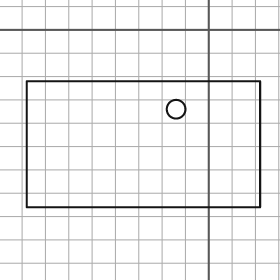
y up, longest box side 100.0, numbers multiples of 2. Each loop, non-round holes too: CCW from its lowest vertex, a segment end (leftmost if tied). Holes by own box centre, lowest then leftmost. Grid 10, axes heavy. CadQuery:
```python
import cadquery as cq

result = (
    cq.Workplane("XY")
    .moveTo(-78.0, -76.0)
    .lineTo(22.0, -76.0)
    .lineTo(22.0, -22.0)
    .lineTo(-78.0, -22.0)
    .close()
    .moveTo(-14.0, -34.0)
    .circle(4.0)
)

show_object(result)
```